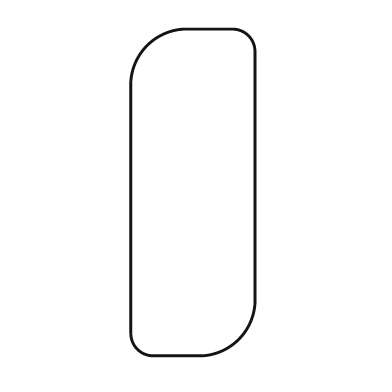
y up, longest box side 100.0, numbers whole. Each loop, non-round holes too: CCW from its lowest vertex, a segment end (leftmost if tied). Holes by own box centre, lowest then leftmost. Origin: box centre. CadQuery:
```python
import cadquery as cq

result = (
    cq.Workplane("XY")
    .moveTo(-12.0, -50.0)
    .lineTo(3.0, -50.0)
    .threePointArc((14.0, -45.0), (19.0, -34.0))
    .lineTo(19.0, 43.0)
    .threePointArc((17.0, 48.0), (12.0, 50.0))
    .lineTo(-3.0, 50.0)
    .threePointArc((-14.0, 45.0), (-19.0, 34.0))
    .lineTo(-19.0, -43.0)
    .threePointArc((-17.0, -48.0), (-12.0, -50.0))
    .close()
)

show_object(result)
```